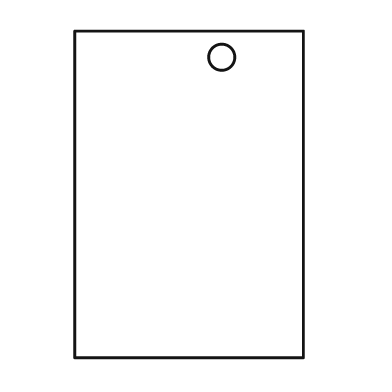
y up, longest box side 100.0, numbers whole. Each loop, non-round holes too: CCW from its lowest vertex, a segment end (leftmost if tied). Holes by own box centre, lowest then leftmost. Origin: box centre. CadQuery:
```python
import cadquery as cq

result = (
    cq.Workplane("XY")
    .moveTo(-35.0, -50.0)
    .lineTo(35.0, -50.0)
    .lineTo(35.0, 50.0)
    .lineTo(-35.0, 50.0)
    .close()
    .moveTo(10.0, 42.0)
    .circle(4.0)
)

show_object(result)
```